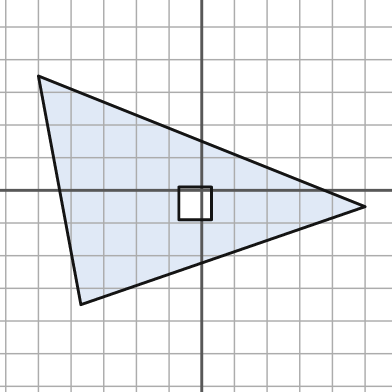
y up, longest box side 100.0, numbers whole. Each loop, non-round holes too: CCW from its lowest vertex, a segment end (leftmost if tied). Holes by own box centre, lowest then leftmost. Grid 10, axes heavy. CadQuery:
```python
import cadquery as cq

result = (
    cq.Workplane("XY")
    .moveTo(-37.0, -35.0)
    .lineTo(50.0, -5.0)
    .lineTo(-50.0, 35.0)
    .close()
    .moveTo(-7.0, -9.0)
    .lineTo(3.0, -9.0)
    .lineTo(3.0, 1.0)
    .lineTo(-7.0, 1.0)
    .close()
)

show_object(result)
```